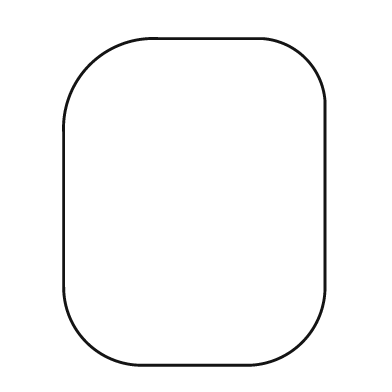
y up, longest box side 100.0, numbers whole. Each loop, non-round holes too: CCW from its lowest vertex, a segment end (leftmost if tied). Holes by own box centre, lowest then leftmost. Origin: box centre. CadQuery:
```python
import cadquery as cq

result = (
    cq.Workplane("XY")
    .moveTo(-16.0, -50.0)
    .lineTo(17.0, -50.0)
    .threePointArc((33.0, -43.0), (40.0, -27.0))
    .lineTo(40.0, 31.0)
    .threePointArc((34.0, 44.0), (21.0, 50.0))
    .lineTo(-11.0, 50.0)
    .threePointArc((-32.0, 42.0), (-40.0, 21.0))
    .lineTo(-40.0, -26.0)
    .threePointArc((-33.0, -43.0), (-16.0, -50.0))
    .close()
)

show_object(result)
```